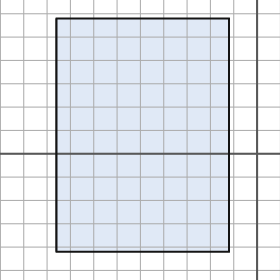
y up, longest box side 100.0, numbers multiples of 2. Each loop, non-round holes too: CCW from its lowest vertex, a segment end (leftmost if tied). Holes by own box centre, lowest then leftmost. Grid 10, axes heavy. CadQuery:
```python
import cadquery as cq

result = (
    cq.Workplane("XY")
    .moveTo(-86.0, -42.0)
    .lineTo(-12.0, -42.0)
    .lineTo(-12.0, 58.0)
    .lineTo(-86.0, 58.0)
    .close()
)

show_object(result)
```